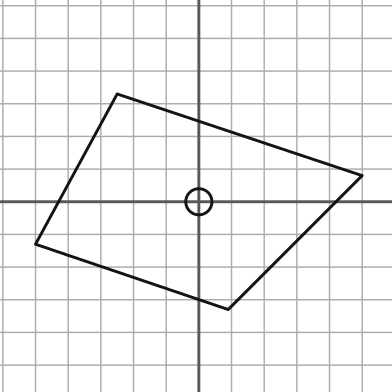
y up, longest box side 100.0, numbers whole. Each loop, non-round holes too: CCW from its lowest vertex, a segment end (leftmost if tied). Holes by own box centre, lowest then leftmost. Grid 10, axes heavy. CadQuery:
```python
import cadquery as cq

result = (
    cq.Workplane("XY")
    .moveTo(9.0, -33.0)
    .lineTo(50.0, 8.0)
    .lineTo(-25.0, 33.0)
    .lineTo(-50.0, -13.0)
    .close()
    .moveTo(0.0, 0.0)
    .circle(4.0)
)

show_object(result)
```